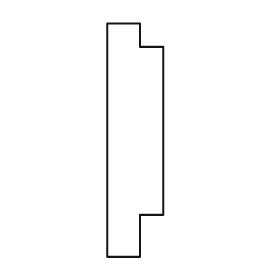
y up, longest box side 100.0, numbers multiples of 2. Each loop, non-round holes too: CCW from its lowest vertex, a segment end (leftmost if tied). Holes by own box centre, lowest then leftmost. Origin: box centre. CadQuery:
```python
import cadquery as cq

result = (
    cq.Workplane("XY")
    .moveTo(-12.0, -50.0)
    .lineTo(2.0, -50.0)
    .lineTo(2.0, -32.0)
    .lineTo(12.0, -32.0)
    .lineTo(12.0, 40.0)
    .lineTo(2.0, 40.0)
    .lineTo(2.0, 50.0)
    .lineTo(-12.0, 50.0)
    .close()
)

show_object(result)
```